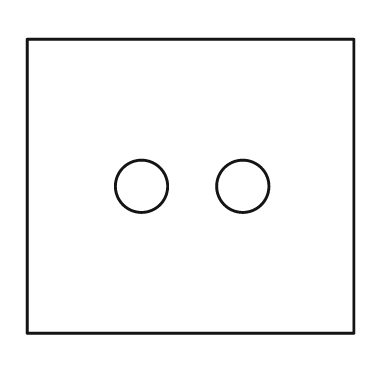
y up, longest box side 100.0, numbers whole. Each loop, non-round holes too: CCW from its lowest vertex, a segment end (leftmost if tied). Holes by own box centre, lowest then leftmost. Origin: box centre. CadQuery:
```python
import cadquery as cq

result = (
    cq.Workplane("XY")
    .moveTo(-50.0, -45.0)
    .lineTo(50.0, -45.0)
    .lineTo(50.0, 45.0)
    .lineTo(-50.0, 45.0)
    .close()
    .moveTo(-15.0, 0.0)
    .circle(8.0)
    .moveTo(16.0, 0.0)
    .circle(8.0)
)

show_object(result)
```